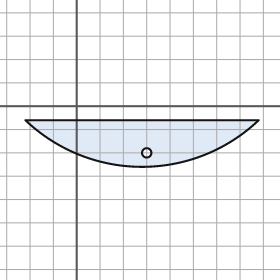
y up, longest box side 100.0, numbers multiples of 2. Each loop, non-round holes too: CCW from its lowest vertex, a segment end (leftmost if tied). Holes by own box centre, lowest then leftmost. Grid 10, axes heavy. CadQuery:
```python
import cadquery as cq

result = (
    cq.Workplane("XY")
    .moveTo(-22.0, -6.0)
    .threePointArc((28.0, -26.0), (78.0, -6.0))
    .close()
    .moveTo(30.0, -20.0)
    .circle(2.0)
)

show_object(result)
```